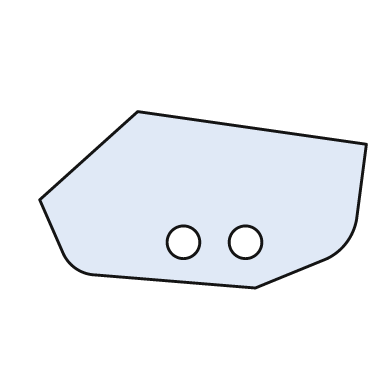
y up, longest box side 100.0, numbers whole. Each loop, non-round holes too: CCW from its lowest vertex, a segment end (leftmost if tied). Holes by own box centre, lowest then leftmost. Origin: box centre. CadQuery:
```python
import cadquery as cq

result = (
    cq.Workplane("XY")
    .moveTo(16.0, -27.0)
    .lineTo(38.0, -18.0)
    .threePointArc((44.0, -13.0), (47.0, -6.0))
    .lineTo(50.0, 17.0)
    .lineTo(-20.0, 27.0)
    .lineTo(-50.0, 0.0)
    .lineTo(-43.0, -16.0)
    .threePointArc((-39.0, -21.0), (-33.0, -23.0))
    .close()
    .moveTo(-6.0, -13.0)
    .circle(5.0)
    .moveTo(13.0, -13.0)
    .circle(5.0)
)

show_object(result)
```